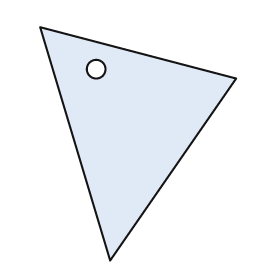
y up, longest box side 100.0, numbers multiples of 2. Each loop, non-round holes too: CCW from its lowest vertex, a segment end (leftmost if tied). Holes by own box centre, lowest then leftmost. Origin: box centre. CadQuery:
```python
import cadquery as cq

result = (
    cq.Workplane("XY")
    .moveTo(-12.0, -50.0)
    .lineTo(42.0, 28.0)
    .lineTo(-42.0, 50.0)
    .close()
    .moveTo(-18.0, 32.0)
    .circle(4.0)
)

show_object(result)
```